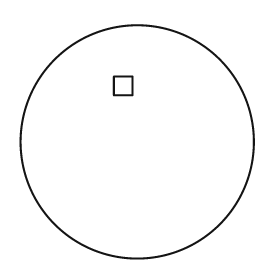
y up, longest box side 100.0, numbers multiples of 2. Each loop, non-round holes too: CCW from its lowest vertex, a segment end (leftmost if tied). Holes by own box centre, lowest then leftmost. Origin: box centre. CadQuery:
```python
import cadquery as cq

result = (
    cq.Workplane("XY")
    .moveTo(0.0, 0.0)
    .circle(50.0)
    .moveTo(-10.0, 20.0)
    .lineTo(-2.0, 20.0)
    .lineTo(-2.0, 28.0)
    .lineTo(-10.0, 28.0)
    .close()
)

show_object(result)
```